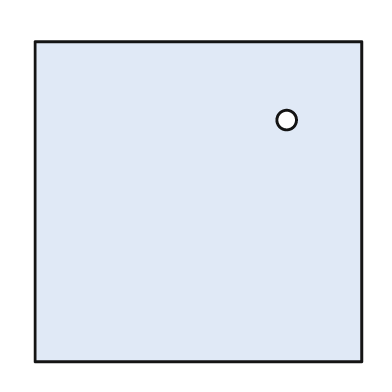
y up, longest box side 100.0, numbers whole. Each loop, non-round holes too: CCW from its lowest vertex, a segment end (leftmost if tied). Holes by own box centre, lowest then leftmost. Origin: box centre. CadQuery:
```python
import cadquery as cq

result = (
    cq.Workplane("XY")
    .moveTo(-50.0, -49.0)
    .lineTo(50.0, -49.0)
    .lineTo(50.0, 49.0)
    .lineTo(-50.0, 49.0)
    .close()
    .moveTo(27.0, 25.0)
    .circle(3.0)
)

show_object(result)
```